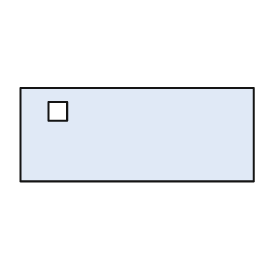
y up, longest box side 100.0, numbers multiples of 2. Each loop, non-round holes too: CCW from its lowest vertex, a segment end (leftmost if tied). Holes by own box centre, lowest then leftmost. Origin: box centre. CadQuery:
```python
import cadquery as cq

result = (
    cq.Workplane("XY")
    .moveTo(-50.0, -20.0)
    .lineTo(50.0, -20.0)
    .lineTo(50.0, 20.0)
    .lineTo(-50.0, 20.0)
    .close()
    .moveTo(-38.0, 6.0)
    .lineTo(-30.0, 6.0)
    .lineTo(-30.0, 14.0)
    .lineTo(-38.0, 14.0)
    .close()
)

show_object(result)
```